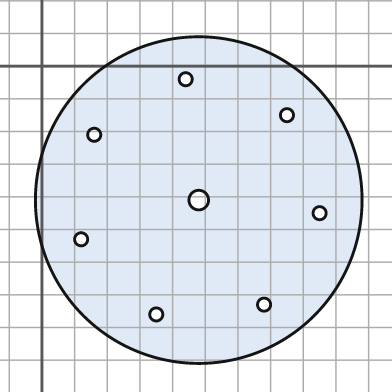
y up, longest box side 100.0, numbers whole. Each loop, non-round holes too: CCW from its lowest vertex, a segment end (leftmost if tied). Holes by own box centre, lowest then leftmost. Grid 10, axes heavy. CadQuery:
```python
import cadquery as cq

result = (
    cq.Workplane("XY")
    .moveTo(48.0, -41.0)
    .circle(50.0)
    .moveTo(35.0, -76.0)
    .circle(2.0)
    .moveTo(68.0, -73.0)
    .circle(2.0)
    .moveTo(12.0, -53.0)
    .circle(2.0)
    .moveTo(85.0, -45.0)
    .circle(2.0)
    .moveTo(48.0, -41.0)
    .circle(3.0)
    .moveTo(16.0, -21.0)
    .circle(2.0)
    .moveTo(75.0, -15.0)
    .circle(2.0)
    .moveTo(44.0, -4.0)
    .circle(2.0)
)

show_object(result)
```